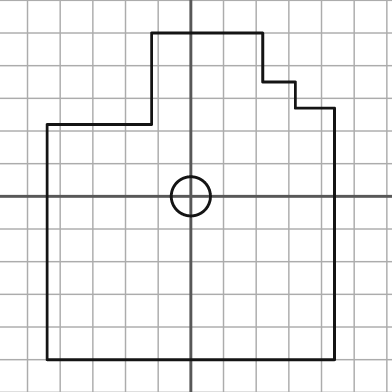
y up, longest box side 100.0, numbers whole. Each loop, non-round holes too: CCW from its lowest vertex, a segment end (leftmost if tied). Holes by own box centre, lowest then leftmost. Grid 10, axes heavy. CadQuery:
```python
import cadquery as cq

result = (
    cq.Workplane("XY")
    .moveTo(-44.0, -50.0)
    .lineTo(44.0, -50.0)
    .lineTo(44.0, 27.0)
    .lineTo(32.0, 27.0)
    .lineTo(32.0, 35.0)
    .lineTo(22.0, 35.0)
    .lineTo(22.0, 50.0)
    .lineTo(-12.0, 50.0)
    .lineTo(-12.0, 22.0)
    .lineTo(-44.0, 22.0)
    .close()
    .moveTo(0.0, 0.0)
    .circle(6.0)
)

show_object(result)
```